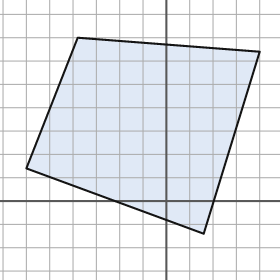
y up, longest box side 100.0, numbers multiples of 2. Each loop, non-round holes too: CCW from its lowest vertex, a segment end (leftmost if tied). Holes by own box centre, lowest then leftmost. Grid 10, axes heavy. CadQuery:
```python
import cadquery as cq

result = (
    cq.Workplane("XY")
    .moveTo(16.0, -14.0)
    .lineTo(40.0, 64.0)
    .lineTo(-38.0, 70.0)
    .lineTo(-60.0, 14.0)
    .close()
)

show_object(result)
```